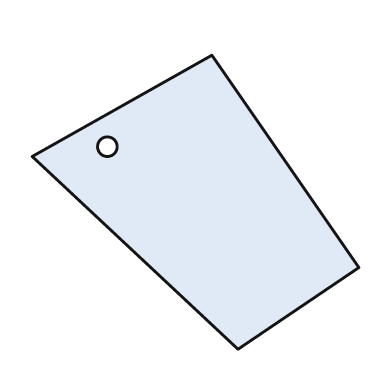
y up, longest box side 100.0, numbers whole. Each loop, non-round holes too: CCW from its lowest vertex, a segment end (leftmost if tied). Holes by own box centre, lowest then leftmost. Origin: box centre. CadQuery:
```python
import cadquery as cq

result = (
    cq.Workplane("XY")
    .moveTo(13.0, -45.0)
    .lineTo(50.0, -20.0)
    .lineTo(5.0, 45.0)
    .lineTo(-50.0, 14.0)
    .close()
    .moveTo(-27.0, 17.0)
    .circle(3.0)
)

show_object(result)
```